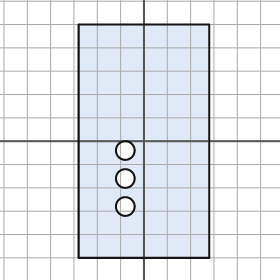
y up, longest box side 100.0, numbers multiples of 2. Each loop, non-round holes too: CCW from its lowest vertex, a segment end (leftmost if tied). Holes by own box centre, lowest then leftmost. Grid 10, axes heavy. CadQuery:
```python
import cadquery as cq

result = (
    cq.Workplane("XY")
    .moveTo(-28.0, -50.0)
    .lineTo(28.0, -50.0)
    .lineTo(28.0, 50.0)
    .lineTo(-28.0, 50.0)
    .close()
    .moveTo(-8.0, -28.0)
    .circle(4.0)
    .moveTo(-8.0, -16.0)
    .circle(4.0)
    .moveTo(-8.0, -4.0)
    .circle(4.0)
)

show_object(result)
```